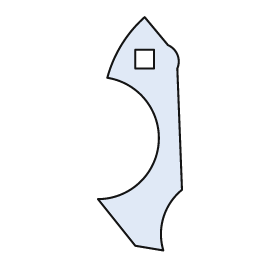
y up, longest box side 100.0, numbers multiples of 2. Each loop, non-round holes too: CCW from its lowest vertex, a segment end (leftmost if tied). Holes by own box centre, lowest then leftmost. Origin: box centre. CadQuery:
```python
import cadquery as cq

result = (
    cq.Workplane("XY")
    .moveTo(10.0, -50.0)
    .threePointArc((10.0, -36.0), (18.0, -24.0))
    .lineTo(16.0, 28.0)
    .threePointArc((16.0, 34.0), (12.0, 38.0))
    .lineTo(2.0, 50.0)
    .threePointArc((-8.0, 38.0), (-14.0, 24.0))
    .threePointArc((8.0, -4.0), (-18.0, -28.0))
    .lineTo(-2.0, -48.0)
    .close()
    .moveTo(-2.0, 28.0)
    .lineTo(6.0, 28.0)
    .lineTo(6.0, 36.0)
    .lineTo(-2.0, 36.0)
    .close()
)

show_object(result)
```